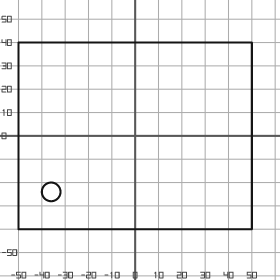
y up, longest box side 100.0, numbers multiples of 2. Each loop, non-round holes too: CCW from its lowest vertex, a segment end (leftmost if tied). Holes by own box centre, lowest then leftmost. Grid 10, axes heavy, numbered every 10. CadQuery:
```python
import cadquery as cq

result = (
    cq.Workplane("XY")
    .moveTo(-50.0, -40.0)
    .lineTo(50.0, -40.0)
    .lineTo(50.0, 40.0)
    .lineTo(-50.0, 40.0)
    .close()
    .moveTo(-36.0, -24.0)
    .circle(4.0)
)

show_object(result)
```